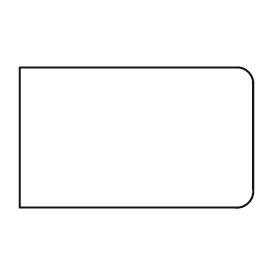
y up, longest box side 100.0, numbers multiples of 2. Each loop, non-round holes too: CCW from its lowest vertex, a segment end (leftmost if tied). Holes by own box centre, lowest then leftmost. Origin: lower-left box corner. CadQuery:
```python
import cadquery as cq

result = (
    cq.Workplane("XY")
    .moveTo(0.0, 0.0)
    .lineTo(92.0, 0.0)
    .threePointArc((98.0, 2.0), (100.0, 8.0))
    .lineTo(100.0, 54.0)
    .threePointArc((98.0, 58.0), (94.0, 60.0))
    .lineTo(0.0, 60.0)
    .close()
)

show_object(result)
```